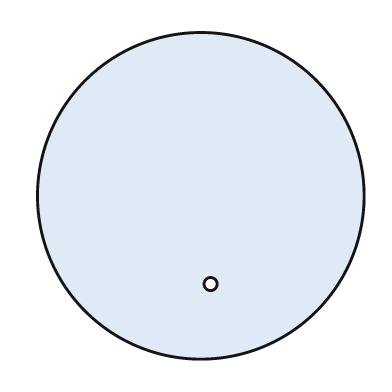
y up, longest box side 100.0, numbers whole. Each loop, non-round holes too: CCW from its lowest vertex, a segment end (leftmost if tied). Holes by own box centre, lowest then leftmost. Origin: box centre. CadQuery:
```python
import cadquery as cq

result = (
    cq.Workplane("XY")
    .moveTo(0.0, 0.0)
    .circle(50.0)
    .moveTo(3.0, -27.0)
    .circle(2.0)
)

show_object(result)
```